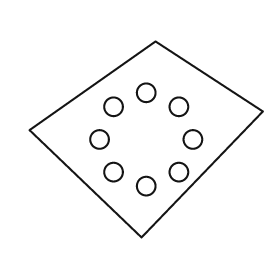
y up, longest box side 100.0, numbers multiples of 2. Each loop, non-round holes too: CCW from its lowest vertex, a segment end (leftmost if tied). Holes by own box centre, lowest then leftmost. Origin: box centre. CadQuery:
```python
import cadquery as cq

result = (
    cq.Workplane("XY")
    .moveTo(-2.0, -42.0)
    .lineTo(50.0, 12.0)
    .lineTo(4.0, 42.0)
    .lineTo(-50.0, 4.0)
    .close()
    .moveTo(0.0, -20.0)
    .circle(4.0)
    .moveTo(-14.0, -14.0)
    .circle(4.0)
    .moveTo(14.0, -14.0)
    .circle(4.0)
    .moveTo(-20.0, 0.0)
    .circle(4.0)
    .moveTo(20.0, 0.0)
    .circle(4.0)
    .moveTo(-14.0, 14.0)
    .circle(4.0)
    .moveTo(14.0, 14.0)
    .circle(4.0)
    .moveTo(0.0, 20.0)
    .circle(4.0)
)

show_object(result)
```